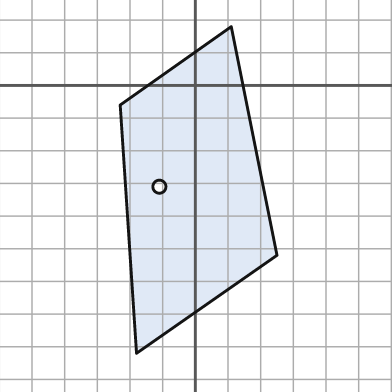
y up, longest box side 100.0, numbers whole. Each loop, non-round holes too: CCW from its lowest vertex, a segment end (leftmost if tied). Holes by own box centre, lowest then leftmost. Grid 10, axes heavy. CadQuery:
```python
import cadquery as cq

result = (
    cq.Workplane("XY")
    .moveTo(-18.0, -82.0)
    .lineTo(25.0, -52.0)
    .lineTo(11.0, 18.0)
    .lineTo(-23.0, -6.0)
    .close()
    .moveTo(-11.0, -31.0)
    .circle(2.0)
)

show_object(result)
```